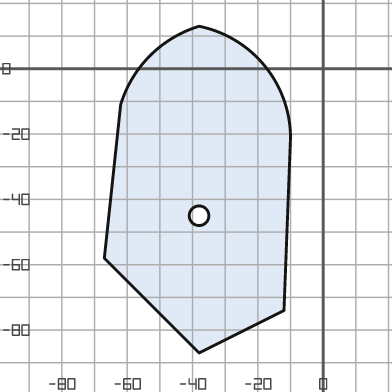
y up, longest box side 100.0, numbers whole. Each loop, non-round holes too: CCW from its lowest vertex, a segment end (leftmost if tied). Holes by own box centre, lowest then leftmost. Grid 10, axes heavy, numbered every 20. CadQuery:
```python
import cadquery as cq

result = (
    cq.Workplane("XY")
    .moveTo(-38.0, -87.0)
    .lineTo(-12.0, -74.0)
    .lineTo(-10.0, -21.0)
    .threePointArc((-18.0, 1.0), (-38.0, 13.0))
    .threePointArc((-53.0, 4.0), (-62.0, -11.0))
    .lineTo(-67.0, -58.0)
    .close()
    .moveTo(-38.0, -45.0)
    .circle(3.0)
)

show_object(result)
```